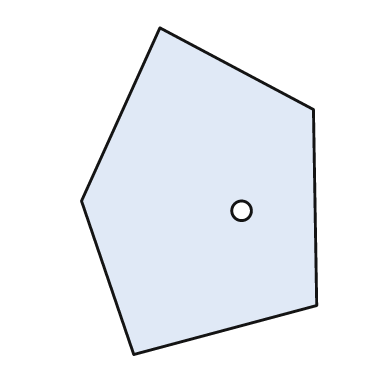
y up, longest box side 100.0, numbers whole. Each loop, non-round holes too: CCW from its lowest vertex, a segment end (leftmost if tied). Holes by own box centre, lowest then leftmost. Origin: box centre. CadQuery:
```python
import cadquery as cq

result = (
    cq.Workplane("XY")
    .moveTo(-20.0, -50.0)
    .lineTo(36.0, -35.0)
    .lineTo(35.0, 25.0)
    .lineTo(-12.0, 50.0)
    .lineTo(-36.0, -3.0)
    .close()
    .moveTo(13.0, -6.0)
    .circle(3.0)
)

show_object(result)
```